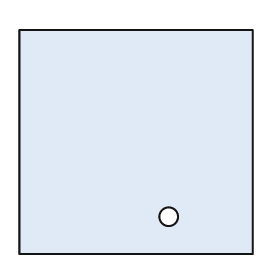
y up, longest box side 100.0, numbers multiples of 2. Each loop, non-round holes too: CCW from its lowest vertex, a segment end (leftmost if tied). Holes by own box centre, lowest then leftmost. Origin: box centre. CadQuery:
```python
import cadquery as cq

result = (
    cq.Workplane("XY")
    .moveTo(-50.0, -48.0)
    .lineTo(50.0, -48.0)
    .lineTo(50.0, 48.0)
    .lineTo(-50.0, 48.0)
    .close()
    .moveTo(14.0, -32.0)
    .circle(4.0)
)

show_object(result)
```